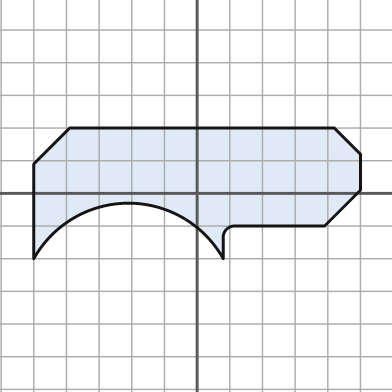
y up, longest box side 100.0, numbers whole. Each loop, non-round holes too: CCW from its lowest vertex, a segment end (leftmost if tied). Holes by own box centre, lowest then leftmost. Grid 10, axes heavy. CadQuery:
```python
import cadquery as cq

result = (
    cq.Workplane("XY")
    .moveTo(-50.0, -20.0)
    .threePointArc((-21.0, -3.0), (8.0, -20.0))
    .lineTo(8.0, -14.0)
    .threePointArc((9.0, -11.0), (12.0, -10.0))
    .lineTo(39.0, -10.0)
    .lineTo(50.0, 1.0)
    .lineTo(50.0, 12.0)
    .lineTo(42.0, 20.0)
    .lineTo(-39.0, 20.0)
    .lineTo(-50.0, 9.0)
    .close()
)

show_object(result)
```